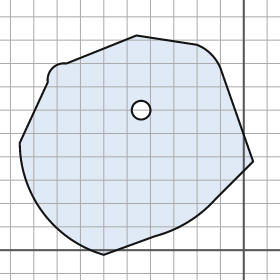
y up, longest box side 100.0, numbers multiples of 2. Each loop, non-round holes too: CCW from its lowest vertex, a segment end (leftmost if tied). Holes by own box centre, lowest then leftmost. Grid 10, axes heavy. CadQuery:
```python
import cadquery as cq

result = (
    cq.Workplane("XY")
    .moveTo(-60.0, -2.0)
    .lineTo(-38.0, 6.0)
    .threePointArc((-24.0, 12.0), (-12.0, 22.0))
    .lineTo(4.0, 38.0)
    .lineTo(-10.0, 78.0)
    .threePointArc((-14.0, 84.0), (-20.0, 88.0))
    .lineTo(-46.0, 92.0)
    .lineTo(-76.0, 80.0)
    .threePointArc((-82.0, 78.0), (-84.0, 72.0))
    .lineTo(-96.0, 46.0)
    .threePointArc((-86.0, 16.0), (-60.0, -2.0))
    .close()
    .moveTo(-44.0, 60.0)
    .circle(4.0)
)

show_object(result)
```